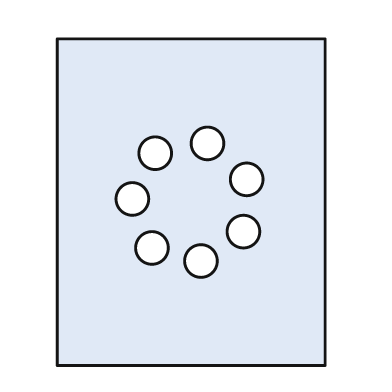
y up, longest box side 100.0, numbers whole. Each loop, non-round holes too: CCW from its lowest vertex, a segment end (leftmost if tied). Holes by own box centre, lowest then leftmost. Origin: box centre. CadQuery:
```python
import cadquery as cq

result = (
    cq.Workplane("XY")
    .moveTo(-41.0, -50.0)
    .lineTo(41.0, -50.0)
    .lineTo(41.0, 50.0)
    .lineTo(-41.0, 50.0)
    .close()
    .moveTo(3.0, -18.0)
    .circle(5.0)
    .moveTo(-12.0, -14.0)
    .circle(5.0)
    .moveTo(16.0, -9.0)
    .circle(5.0)
    .moveTo(-18.0, 1.0)
    .circle(5.0)
    .moveTo(17.0, 7.0)
    .circle(5.0)
    .moveTo(-11.0, 15.0)
    .circle(5.0)
    .moveTo(5.0, 18.0)
    .circle(5.0)
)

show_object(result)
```